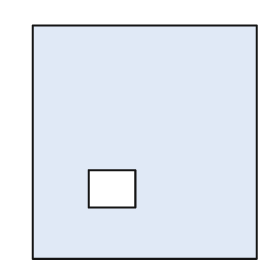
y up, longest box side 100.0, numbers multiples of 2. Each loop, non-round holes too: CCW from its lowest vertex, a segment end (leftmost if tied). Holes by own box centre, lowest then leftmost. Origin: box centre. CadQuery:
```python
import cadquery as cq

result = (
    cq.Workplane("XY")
    .moveTo(-48.0, -50.0)
    .lineTo(48.0, -50.0)
    .lineTo(48.0, 50.0)
    .lineTo(-48.0, 50.0)
    .close()
    .moveTo(-24.0, -28.0)
    .lineTo(-4.0, -28.0)
    .lineTo(-4.0, -12.0)
    .lineTo(-24.0, -12.0)
    .close()
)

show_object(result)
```